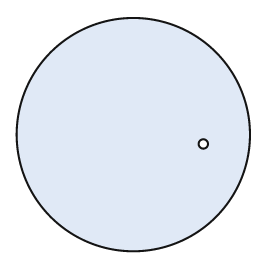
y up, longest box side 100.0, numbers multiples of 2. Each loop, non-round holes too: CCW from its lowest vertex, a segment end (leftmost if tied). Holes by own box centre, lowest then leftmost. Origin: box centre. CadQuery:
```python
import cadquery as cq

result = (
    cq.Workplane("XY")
    .moveTo(0.0, 0.0)
    .circle(50.0)
    .moveTo(30.0, -4.0)
    .circle(2.0)
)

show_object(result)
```